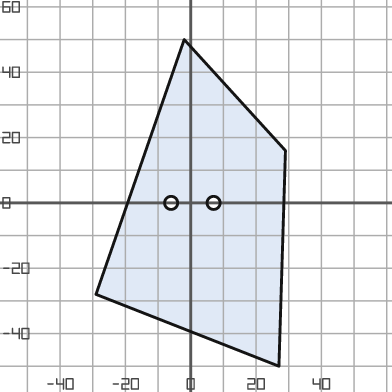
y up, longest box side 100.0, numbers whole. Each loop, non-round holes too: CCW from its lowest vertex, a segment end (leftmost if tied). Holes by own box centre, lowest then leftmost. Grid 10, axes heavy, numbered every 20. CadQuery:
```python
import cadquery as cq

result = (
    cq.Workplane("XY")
    .moveTo(27.0, -50.0)
    .lineTo(29.0, 16.0)
    .lineTo(-2.0, 50.0)
    .lineTo(-29.0, -28.0)
    .close()
    .moveTo(-6.0, 0.0)
    .circle(2.0)
    .moveTo(7.0, 0.0)
    .circle(2.0)
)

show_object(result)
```